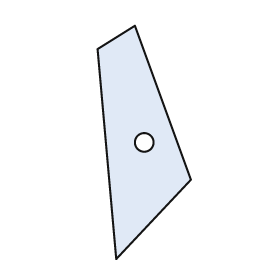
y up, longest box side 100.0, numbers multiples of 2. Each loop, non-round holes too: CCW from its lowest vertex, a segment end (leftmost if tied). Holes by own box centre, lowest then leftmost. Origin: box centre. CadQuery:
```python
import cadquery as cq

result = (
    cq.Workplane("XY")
    .moveTo(-12.0, -50.0)
    .lineTo(20.0, -16.0)
    .lineTo(-4.0, 50.0)
    .lineTo(-20.0, 40.0)
    .close()
    .moveTo(0.0, 0.0)
    .circle(4.0)
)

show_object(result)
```